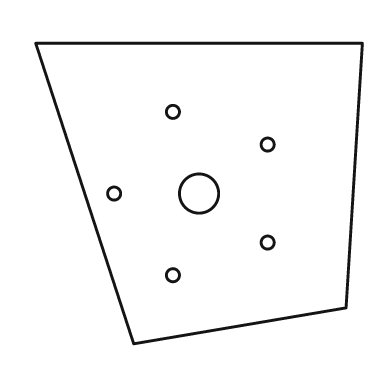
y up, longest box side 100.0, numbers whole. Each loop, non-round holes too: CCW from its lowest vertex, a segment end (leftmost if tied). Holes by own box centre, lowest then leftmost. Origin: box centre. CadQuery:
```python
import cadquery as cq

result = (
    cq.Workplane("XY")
    .moveTo(-20.0, -46.0)
    .lineTo(45.0, -35.0)
    .lineTo(50.0, 46.0)
    .lineTo(-50.0, 46.0)
    .close()
    .moveTo(-8.0, -25.0)
    .circle(2.0)
    .moveTo(21.0, -15.0)
    .circle(2.0)
    .moveTo(-26.0, 0.0)
    .circle(2.0)
    .moveTo(0.0, 0.0)
    .circle(6.0)
    .moveTo(21.0, 15.0)
    .circle(2.0)
    .moveTo(-8.0, 25.0)
    .circle(2.0)
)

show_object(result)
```